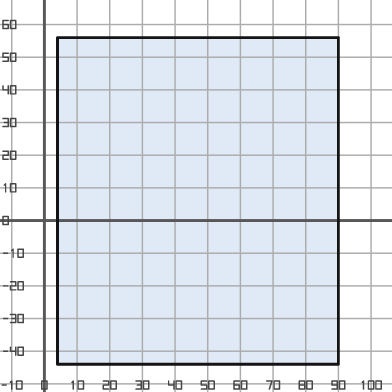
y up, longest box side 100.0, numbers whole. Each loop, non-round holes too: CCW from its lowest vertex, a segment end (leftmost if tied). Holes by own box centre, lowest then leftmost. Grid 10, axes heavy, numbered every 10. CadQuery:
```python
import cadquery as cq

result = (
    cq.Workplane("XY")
    .moveTo(4.0, -44.0)
    .lineTo(90.0, -44.0)
    .lineTo(90.0, 56.0)
    .lineTo(4.0, 56.0)
    .close()
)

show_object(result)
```